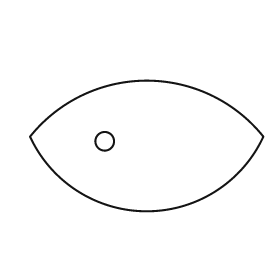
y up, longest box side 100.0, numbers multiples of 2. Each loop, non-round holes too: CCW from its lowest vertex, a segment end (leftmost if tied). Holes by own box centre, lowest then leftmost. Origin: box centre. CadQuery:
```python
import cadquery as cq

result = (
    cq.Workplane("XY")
    .moveTo(-50.0, 4.0)
    .threePointArc((0.0, -28.0), (50.0, 4.0))
    .threePointArc((0.0, 28.0), (-50.0, 4.0))
    .close()
    .moveTo(-18.0, 2.0)
    .circle(4.0)
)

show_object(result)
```